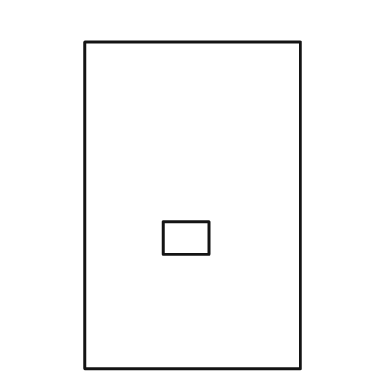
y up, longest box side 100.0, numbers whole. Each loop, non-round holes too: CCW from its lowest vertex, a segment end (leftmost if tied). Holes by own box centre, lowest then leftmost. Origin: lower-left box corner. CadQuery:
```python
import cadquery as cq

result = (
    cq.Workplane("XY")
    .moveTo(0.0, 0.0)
    .lineTo(66.0, 0.0)
    .lineTo(66.0, 100.0)
    .lineTo(0.0, 100.0)
    .close()
    .moveTo(24.0, 35.0)
    .lineTo(38.0, 35.0)
    .lineTo(38.0, 45.0)
    .lineTo(24.0, 45.0)
    .close()
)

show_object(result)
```